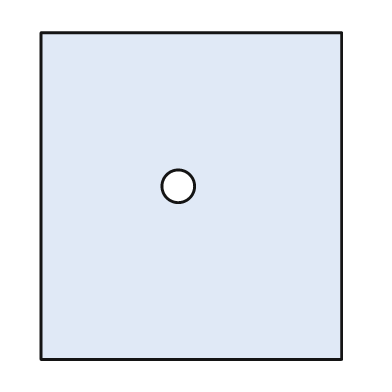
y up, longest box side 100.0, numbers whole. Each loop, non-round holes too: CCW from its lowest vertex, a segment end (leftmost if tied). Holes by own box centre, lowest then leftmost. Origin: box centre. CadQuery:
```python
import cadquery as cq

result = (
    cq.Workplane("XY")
    .moveTo(-46.0, -50.0)
    .lineTo(46.0, -50.0)
    .lineTo(46.0, 50.0)
    .lineTo(-46.0, 50.0)
    .close()
    .moveTo(-4.0, 3.0)
    .circle(5.0)
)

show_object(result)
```